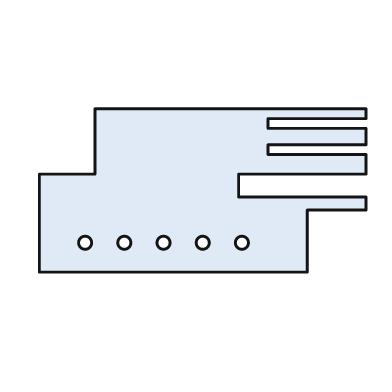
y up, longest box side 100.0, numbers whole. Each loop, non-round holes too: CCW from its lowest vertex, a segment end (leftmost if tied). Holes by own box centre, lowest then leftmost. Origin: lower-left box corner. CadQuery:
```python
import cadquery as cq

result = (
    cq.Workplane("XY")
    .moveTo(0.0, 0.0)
    .lineTo(82.0, 0.0)
    .lineTo(82.0, 19.0)
    .lineTo(100.0, 19.0)
    .lineTo(100.0, 23.0)
    .lineTo(61.0, 23.0)
    .lineTo(61.0, 30.0)
    .lineTo(100.0, 30.0)
    .lineTo(100.0, 36.0)
    .lineTo(70.0, 36.0)
    .lineTo(70.0, 39.0)
    .lineTo(100.0, 39.0)
    .lineTo(100.0, 44.0)
    .lineTo(70.0, 44.0)
    .lineTo(70.0, 47.0)
    .lineTo(100.0, 47.0)
    .lineTo(100.0, 50.0)
    .lineTo(17.0, 50.0)
    .lineTo(17.0, 30.0)
    .lineTo(0.0, 30.0)
    .close()
    .moveTo(14.0, 9.0)
    .circle(2.0)
    .moveTo(26.0, 9.0)
    .circle(2.0)
    .moveTo(38.0, 9.0)
    .circle(2.0)
    .moveTo(50.0, 9.0)
    .circle(2.0)
    .moveTo(62.0, 9.0)
    .circle(2.0)
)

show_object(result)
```